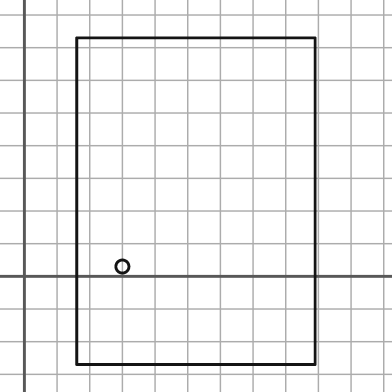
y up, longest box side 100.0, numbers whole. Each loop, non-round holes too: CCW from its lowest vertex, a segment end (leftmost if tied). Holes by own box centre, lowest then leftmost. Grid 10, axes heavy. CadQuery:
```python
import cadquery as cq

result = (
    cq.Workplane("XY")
    .moveTo(16.0, -27.0)
    .lineTo(89.0, -27.0)
    .lineTo(89.0, 73.0)
    .lineTo(16.0, 73.0)
    .close()
    .moveTo(30.0, 3.0)
    .circle(2.0)
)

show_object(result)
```